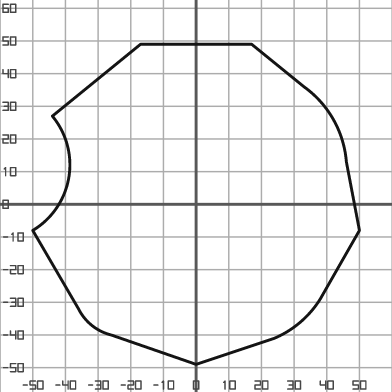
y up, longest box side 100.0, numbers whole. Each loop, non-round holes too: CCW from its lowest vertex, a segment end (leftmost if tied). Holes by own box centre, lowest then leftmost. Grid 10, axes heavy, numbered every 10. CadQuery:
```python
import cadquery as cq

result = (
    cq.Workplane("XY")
    .moveTo(0.0, -49.0)
    .lineTo(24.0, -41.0)
    .threePointArc((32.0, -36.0), (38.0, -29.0))
    .lineTo(50.0, -8.0)
    .lineTo(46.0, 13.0)
    .threePointArc((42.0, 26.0), (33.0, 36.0))
    .lineTo(17.0, 49.0)
    .lineTo(-17.0, 49.0)
    .lineTo(-44.0, 27.0)
    .threePointArc((-39.0, 8.0), (-50.0, -8.0))
    .lineTo(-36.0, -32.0)
    .threePointArc((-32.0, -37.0), (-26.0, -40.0))
    .close()
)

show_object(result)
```